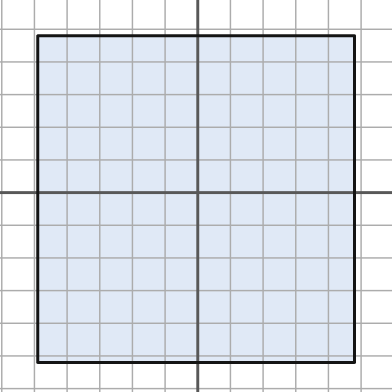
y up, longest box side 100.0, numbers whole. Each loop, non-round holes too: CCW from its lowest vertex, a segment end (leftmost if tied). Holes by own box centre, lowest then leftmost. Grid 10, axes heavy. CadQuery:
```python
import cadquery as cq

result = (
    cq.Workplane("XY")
    .moveTo(-49.0, -52.0)
    .lineTo(48.0, -52.0)
    .lineTo(48.0, 48.0)
    .lineTo(-49.0, 48.0)
    .close()
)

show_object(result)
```